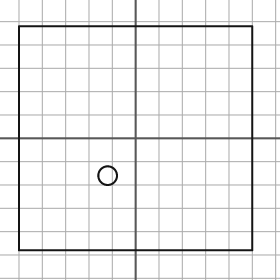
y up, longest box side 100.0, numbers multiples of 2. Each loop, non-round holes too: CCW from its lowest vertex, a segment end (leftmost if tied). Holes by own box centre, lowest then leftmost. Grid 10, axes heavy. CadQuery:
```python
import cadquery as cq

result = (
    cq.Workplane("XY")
    .moveTo(-50.0, -48.0)
    .lineTo(50.0, -48.0)
    .lineTo(50.0, 48.0)
    .lineTo(-50.0, 48.0)
    .close()
    .moveTo(-12.0, -16.0)
    .circle(4.0)
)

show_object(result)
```